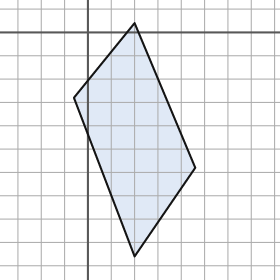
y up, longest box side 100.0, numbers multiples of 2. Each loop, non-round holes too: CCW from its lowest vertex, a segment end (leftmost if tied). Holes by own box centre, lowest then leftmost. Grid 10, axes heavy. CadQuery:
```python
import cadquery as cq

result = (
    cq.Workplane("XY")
    .moveTo(20.0, -96.0)
    .lineTo(46.0, -58.0)
    .lineTo(20.0, 4.0)
    .lineTo(-6.0, -28.0)
    .close()
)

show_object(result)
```